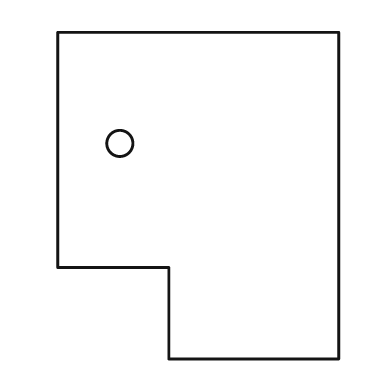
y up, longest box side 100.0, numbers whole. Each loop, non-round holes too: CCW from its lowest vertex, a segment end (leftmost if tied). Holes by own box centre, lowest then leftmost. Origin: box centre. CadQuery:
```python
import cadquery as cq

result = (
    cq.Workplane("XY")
    .moveTo(-9.0, -50.0)
    .lineTo(43.0, -50.0)
    .lineTo(43.0, 50.0)
    .lineTo(-43.0, 50.0)
    .lineTo(-43.0, -22.0)
    .lineTo(-9.0, -22.0)
    .close()
    .moveTo(-24.0, 16.0)
    .circle(4.0)
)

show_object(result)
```